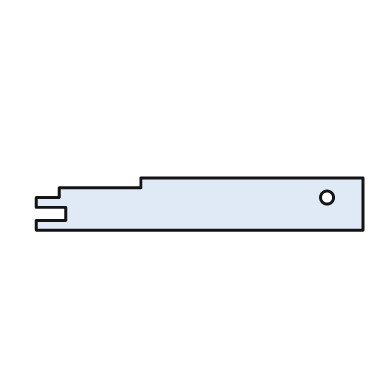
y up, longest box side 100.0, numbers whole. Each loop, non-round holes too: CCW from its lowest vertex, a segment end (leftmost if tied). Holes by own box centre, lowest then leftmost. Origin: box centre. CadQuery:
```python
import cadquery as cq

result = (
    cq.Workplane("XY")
    .moveTo(-50.0, -8.0)
    .lineTo(50.0, -8.0)
    .lineTo(50.0, 8.0)
    .lineTo(-18.0, 8.0)
    .lineTo(-18.0, 5.0)
    .lineTo(-43.0, 5.0)
    .lineTo(-43.0, 2.0)
    .lineTo(-50.0, 2.0)
    .lineTo(-50.0, -1.0)
    .lineTo(-41.0, -1.0)
    .lineTo(-41.0, -5.0)
    .lineTo(-50.0, -5.0)
    .close()
    .moveTo(39.0, 2.0)
    .circle(2.0)
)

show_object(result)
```